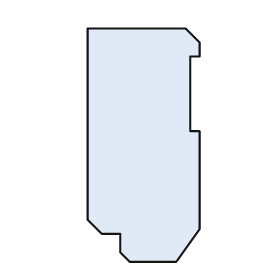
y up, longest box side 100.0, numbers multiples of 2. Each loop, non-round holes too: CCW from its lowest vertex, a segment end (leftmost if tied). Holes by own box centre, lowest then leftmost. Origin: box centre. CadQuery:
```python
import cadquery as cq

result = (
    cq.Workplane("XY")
    .moveTo(-6.0, -50.0)
    .lineTo(14.0, -50.0)
    .lineTo(24.0, -36.0)
    .lineTo(24.0, 6.0)
    .lineTo(20.0, 6.0)
    .lineTo(20.0, 38.0)
    .lineTo(24.0, 38.0)
    .lineTo(24.0, 44.0)
    .lineTo(18.0, 50.0)
    .lineTo(-24.0, 50.0)
    .lineTo(-24.0, -32.0)
    .lineTo(-18.0, -38.0)
    .lineTo(-10.0, -38.0)
    .lineTo(-10.0, -46.0)
    .close()
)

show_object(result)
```